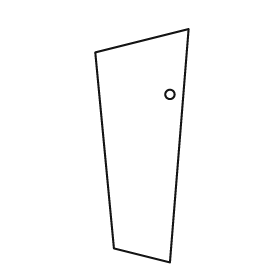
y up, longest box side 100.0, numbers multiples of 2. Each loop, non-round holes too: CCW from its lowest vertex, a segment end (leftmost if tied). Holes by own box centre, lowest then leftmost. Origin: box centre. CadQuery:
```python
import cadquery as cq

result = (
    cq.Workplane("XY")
    .moveTo(12.0, -50.0)
    .lineTo(20.0, 50.0)
    .lineTo(-20.0, 40.0)
    .lineTo(-12.0, -44.0)
    .close()
    .moveTo(12.0, 22.0)
    .circle(2.0)
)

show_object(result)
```